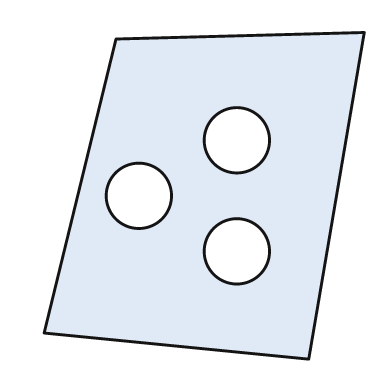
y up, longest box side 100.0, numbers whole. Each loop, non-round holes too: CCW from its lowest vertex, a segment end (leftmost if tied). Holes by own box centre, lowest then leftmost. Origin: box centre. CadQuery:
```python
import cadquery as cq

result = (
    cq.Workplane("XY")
    .moveTo(32.0, -50.0)
    .lineTo(49.0, 50.0)
    .lineTo(-27.0, 48.0)
    .lineTo(-49.0, -42.0)
    .close()
    .moveTo(10.0, -17.0)
    .circle(10.0)
    .moveTo(-20.0, 0.0)
    .circle(10.0)
    .moveTo(10.0, 17.0)
    .circle(10.0)
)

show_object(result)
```